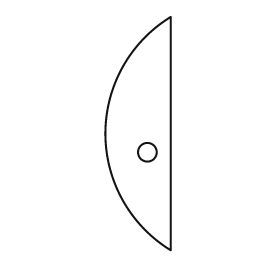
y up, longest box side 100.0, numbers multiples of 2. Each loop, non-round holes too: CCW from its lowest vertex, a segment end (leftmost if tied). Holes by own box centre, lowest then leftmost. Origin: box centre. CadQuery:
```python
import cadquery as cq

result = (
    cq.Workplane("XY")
    .moveTo(14.0, -50.0)
    .lineTo(14.0, 50.0)
    .threePointArc((-14.0, 0.0), (14.0, -50.0))
    .close()
    .moveTo(4.0, -8.0)
    .circle(4.0)
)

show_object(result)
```